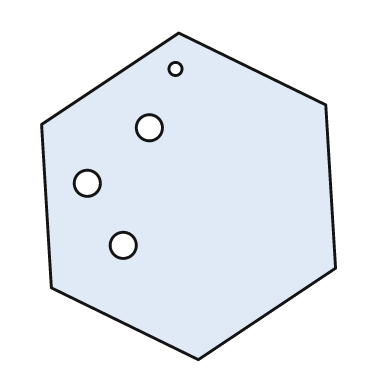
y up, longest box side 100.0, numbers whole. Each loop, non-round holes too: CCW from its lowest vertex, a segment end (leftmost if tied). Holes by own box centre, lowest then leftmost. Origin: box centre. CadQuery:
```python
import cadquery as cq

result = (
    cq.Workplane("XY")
    .moveTo(3.0, -50.0)
    .lineTo(45.0, -22.0)
    .lineTo(42.0, 28.0)
    .lineTo(-3.0, 50.0)
    .lineTo(-45.0, 22.0)
    .lineTo(-42.0, -28.0)
    .close()
    .moveTo(-20.0, -15.0)
    .circle(4.0)
    .moveTo(-31.0, 4.0)
    .circle(4.0)
    .moveTo(-12.0, 21.0)
    .circle(4.0)
    .moveTo(-4.0, 39.0)
    .circle(2.0)
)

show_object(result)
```